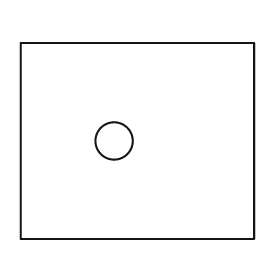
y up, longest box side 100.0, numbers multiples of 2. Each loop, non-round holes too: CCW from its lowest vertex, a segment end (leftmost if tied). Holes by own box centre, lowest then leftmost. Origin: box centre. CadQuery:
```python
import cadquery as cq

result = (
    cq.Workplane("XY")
    .moveTo(-50.0, -42.0)
    .lineTo(50.0, -42.0)
    .lineTo(50.0, 42.0)
    .lineTo(-50.0, 42.0)
    .close()
    .moveTo(-10.0, 0.0)
    .circle(8.0)
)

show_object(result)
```